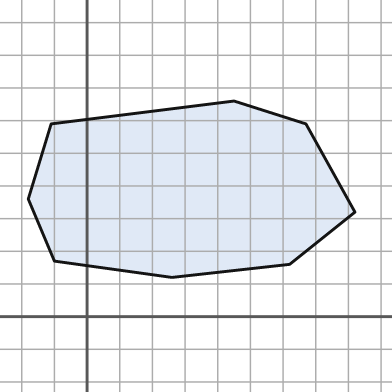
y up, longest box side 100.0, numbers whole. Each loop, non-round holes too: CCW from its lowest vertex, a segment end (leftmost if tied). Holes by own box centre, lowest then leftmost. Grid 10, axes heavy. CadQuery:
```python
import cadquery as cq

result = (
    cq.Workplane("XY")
    .moveTo(26.0, 12.0)
    .lineTo(62.0, 16.0)
    .lineTo(82.0, 32.0)
    .lineTo(67.0, 59.0)
    .lineTo(45.0, 66.0)
    .lineTo(-11.0, 59.0)
    .lineTo(-18.0, 36.0)
    .lineTo(-10.0, 17.0)
    .close()
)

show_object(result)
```